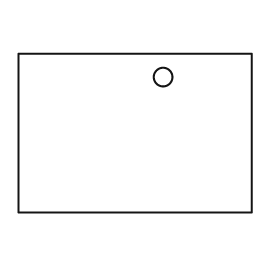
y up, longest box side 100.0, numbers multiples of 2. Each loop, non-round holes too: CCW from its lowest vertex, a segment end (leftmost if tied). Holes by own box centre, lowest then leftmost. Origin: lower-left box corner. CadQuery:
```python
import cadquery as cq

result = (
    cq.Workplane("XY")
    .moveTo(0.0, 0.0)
    .lineTo(100.0, 0.0)
    .lineTo(100.0, 68.0)
    .lineTo(0.0, 68.0)
    .close()
    .moveTo(62.0, 58.0)
    .circle(4.0)
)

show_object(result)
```